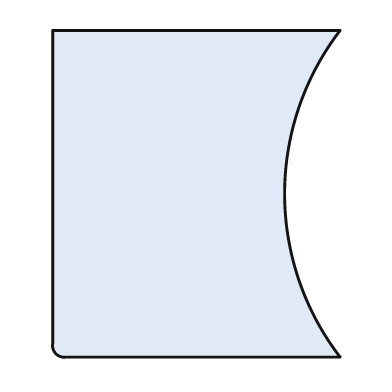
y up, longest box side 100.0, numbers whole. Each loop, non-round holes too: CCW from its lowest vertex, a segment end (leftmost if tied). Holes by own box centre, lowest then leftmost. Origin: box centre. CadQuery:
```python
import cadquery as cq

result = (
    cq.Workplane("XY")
    .moveTo(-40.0, -50.0)
    .lineTo(44.0, -50.0)
    .threePointArc((27.0, 0.0), (44.0, 50.0))
    .lineTo(-44.0, 50.0)
    .lineTo(-44.0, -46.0)
    .threePointArc((-43.0, -49.0), (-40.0, -50.0))
    .close()
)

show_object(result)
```